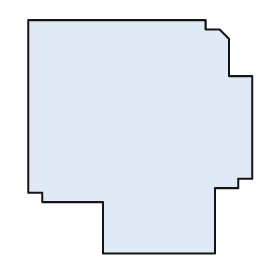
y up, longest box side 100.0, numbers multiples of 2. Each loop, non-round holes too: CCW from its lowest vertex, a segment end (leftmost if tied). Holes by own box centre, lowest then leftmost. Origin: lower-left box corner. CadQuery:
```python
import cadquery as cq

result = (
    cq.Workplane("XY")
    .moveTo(32.0, 0.0)
    .lineTo(80.0, 0.0)
    .lineTo(80.0, 28.0)
    .lineTo(90.0, 28.0)
    .lineTo(90.0, 32.0)
    .lineTo(96.0, 32.0)
    .lineTo(96.0, 76.0)
    .lineTo(86.0, 76.0)
    .lineTo(86.0, 92.0)
    .lineTo(82.0, 96.0)
    .lineTo(76.0, 96.0)
    .lineTo(76.0, 100.0)
    .lineTo(0.0, 100.0)
    .lineTo(0.0, 26.0)
    .lineTo(6.0, 26.0)
    .lineTo(6.0, 22.0)
    .lineTo(32.0, 22.0)
    .close()
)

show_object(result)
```